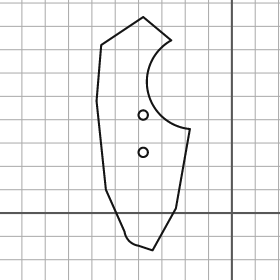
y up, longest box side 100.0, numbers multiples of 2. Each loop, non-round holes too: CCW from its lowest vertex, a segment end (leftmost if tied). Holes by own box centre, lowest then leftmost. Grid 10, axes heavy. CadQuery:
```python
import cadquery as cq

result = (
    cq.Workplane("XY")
    .moveTo(-34.0, -16.0)
    .lineTo(-24.0, 2.0)
    .lineTo(-18.0, 36.0)
    .threePointArc((-36.0, 52.0), (-26.0, 74.0))
    .lineTo(-38.0, 84.0)
    .lineTo(-56.0, 72.0)
    .lineTo(-58.0, 48.0)
    .lineTo(-54.0, 10.0)
    .lineTo(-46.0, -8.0)
    .threePointArc((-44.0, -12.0), (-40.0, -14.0))
    .close()
    .moveTo(-38.0, 26.0)
    .circle(2.0)
    .moveTo(-38.0, 42.0)
    .circle(2.0)
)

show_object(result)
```